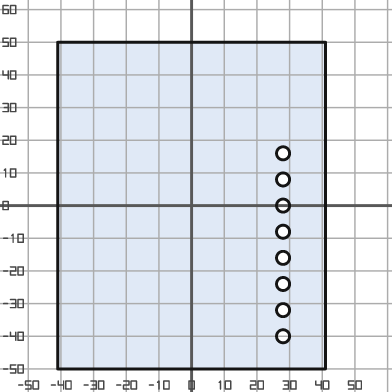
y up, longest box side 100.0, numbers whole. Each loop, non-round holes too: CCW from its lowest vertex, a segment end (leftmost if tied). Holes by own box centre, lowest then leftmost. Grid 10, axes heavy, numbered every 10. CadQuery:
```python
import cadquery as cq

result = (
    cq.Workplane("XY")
    .moveTo(-41.0, -50.0)
    .lineTo(41.0, -50.0)
    .lineTo(41.0, 50.0)
    .lineTo(-41.0, 50.0)
    .close()
    .moveTo(28.0, -40.0)
    .circle(2.0)
    .moveTo(28.0, -32.0)
    .circle(2.0)
    .moveTo(28.0, -24.0)
    .circle(2.0)
    .moveTo(28.0, -16.0)
    .circle(2.0)
    .moveTo(28.0, -8.0)
    .circle(2.0)
    .moveTo(28.0, 0.0)
    .circle(2.0)
    .moveTo(28.0, 8.0)
    .circle(2.0)
    .moveTo(28.0, 16.0)
    .circle(2.0)
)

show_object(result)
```